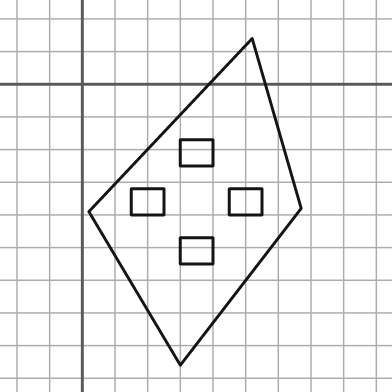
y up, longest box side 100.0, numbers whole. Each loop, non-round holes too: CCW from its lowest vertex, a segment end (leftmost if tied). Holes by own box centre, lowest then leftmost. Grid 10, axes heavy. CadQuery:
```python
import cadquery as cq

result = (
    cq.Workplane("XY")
    .moveTo(30.0, -86.0)
    .lineTo(67.0, -38.0)
    .lineTo(52.0, 14.0)
    .lineTo(2.0, -39.0)
    .close()
    .moveTo(30.0, -55.0)
    .lineTo(40.0, -55.0)
    .lineTo(40.0, -47.0)
    .lineTo(30.0, -47.0)
    .close()
    .moveTo(15.0, -40.0)
    .lineTo(25.0, -40.0)
    .lineTo(25.0, -32.0)
    .lineTo(15.0, -32.0)
    .close()
    .moveTo(45.0, -40.0)
    .lineTo(55.0, -40.0)
    .lineTo(55.0, -32.0)
    .lineTo(45.0, -32.0)
    .close()
    .moveTo(30.0, -25.0)
    .lineTo(40.0, -25.0)
    .lineTo(40.0, -17.0)
    .lineTo(30.0, -17.0)
    .close()
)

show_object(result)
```